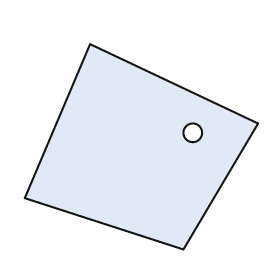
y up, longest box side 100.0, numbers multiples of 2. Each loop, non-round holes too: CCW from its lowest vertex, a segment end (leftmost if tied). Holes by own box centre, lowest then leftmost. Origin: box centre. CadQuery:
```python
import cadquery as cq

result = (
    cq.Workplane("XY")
    .moveTo(18.0, -44.0)
    .lineTo(50.0, 10.0)
    .lineTo(-22.0, 44.0)
    .lineTo(-50.0, -22.0)
    .close()
    .moveTo(22.0, 6.0)
    .circle(4.0)
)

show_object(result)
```